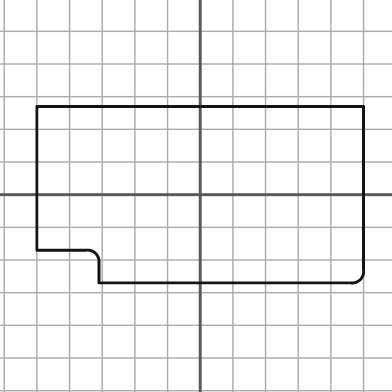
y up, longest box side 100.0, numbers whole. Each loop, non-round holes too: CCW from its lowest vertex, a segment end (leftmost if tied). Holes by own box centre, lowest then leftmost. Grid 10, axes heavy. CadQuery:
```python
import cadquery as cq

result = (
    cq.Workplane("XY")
    .moveTo(-31.0, -27.0)
    .lineTo(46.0, -27.0)
    .threePointArc((49.0, -26.0), (50.0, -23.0))
    .lineTo(50.0, 27.0)
    .lineTo(-50.0, 27.0)
    .lineTo(-50.0, -17.0)
    .lineTo(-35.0, -17.0)
    .threePointArc((-32.0, -18.0), (-31.0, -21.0))
    .close()
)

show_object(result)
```